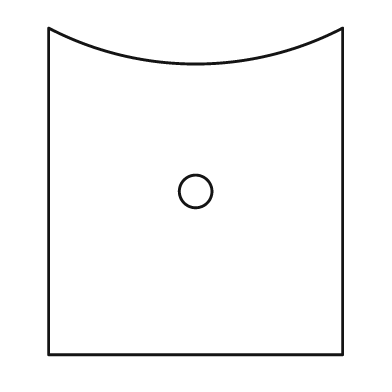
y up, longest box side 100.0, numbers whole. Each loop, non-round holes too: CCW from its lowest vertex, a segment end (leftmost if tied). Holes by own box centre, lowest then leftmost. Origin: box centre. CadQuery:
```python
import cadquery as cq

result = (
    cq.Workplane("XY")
    .moveTo(-45.0, -50.0)
    .lineTo(45.0, -50.0)
    .lineTo(45.0, 50.0)
    .threePointArc((0.0, 39.0), (-45.0, 50.0))
    .close()
    .moveTo(0.0, 0.0)
    .circle(5.0)
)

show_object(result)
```